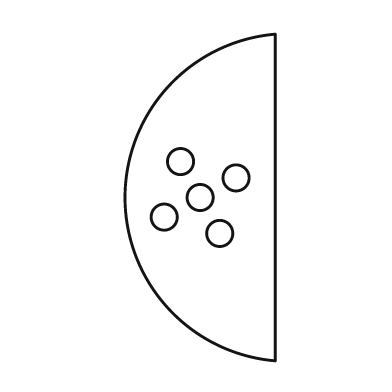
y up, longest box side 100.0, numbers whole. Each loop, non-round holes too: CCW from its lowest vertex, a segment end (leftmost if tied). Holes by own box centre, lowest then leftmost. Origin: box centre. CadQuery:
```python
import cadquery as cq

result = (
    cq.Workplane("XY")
    .moveTo(23.0, -50.0)
    .lineTo(23.0, 50.0)
    .threePointArc((-23.0, 0.0), (23.0, -50.0))
    .close()
    .moveTo(6.0, -11.0)
    .circle(4.0)
    .moveTo(-11.0, -6.0)
    .circle(4.0)
    .moveTo(0.0, 0.0)
    .circle(4.0)
    .moveTo(11.0, 6.0)
    .circle(4.0)
    .moveTo(-6.0, 11.0)
    .circle(4.0)
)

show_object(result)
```